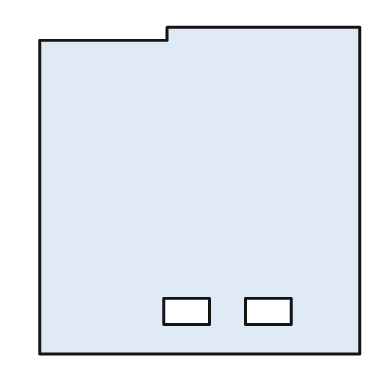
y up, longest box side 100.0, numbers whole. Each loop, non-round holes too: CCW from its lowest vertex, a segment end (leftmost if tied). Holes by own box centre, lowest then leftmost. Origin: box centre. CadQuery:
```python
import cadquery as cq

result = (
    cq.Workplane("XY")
    .moveTo(-49.0, -50.0)
    .lineTo(49.0, -50.0)
    .lineTo(49.0, 50.0)
    .lineTo(-10.0, 50.0)
    .lineTo(-10.0, 46.0)
    .lineTo(-49.0, 46.0)
    .close()
    .moveTo(-11.0, -41.0)
    .lineTo(3.0, -41.0)
    .lineTo(3.0, -33.0)
    .lineTo(-11.0, -33.0)
    .close()
    .moveTo(14.0, -41.0)
    .lineTo(28.0, -41.0)
    .lineTo(28.0, -33.0)
    .lineTo(14.0, -33.0)
    .close()
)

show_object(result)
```